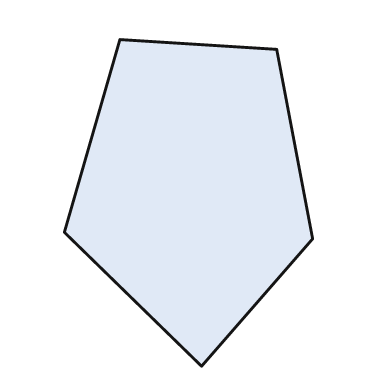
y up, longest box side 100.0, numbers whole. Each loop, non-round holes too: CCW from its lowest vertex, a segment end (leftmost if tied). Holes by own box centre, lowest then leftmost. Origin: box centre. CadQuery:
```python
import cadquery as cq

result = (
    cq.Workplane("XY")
    .moveTo(4.0, -50.0)
    .lineTo(38.0, -11.0)
    .lineTo(27.0, 47.0)
    .lineTo(-21.0, 50.0)
    .lineTo(-38.0, -9.0)
    .close()
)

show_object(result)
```